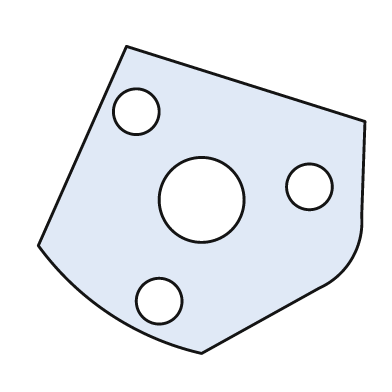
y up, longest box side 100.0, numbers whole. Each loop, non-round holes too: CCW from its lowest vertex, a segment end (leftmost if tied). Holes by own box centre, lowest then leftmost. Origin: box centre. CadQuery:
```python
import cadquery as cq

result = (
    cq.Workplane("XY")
    .moveTo(0.0, -47.0)
    .lineTo(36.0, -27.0)
    .threePointArc((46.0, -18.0), (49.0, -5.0))
    .lineTo(50.0, 24.0)
    .lineTo(-23.0, 47.0)
    .lineTo(-50.0, -14.0)
    .threePointArc((-28.0, -35.0), (0.0, -47.0))
    .close()
    .moveTo(-13.0, -31.0)
    .circle(7.0)
    .moveTo(0.0, 0.0)
    .circle(13.0)
    .moveTo(33.0, 4.0)
    .circle(7.0)
    .moveTo(-20.0, 27.0)
    .circle(7.0)
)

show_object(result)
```